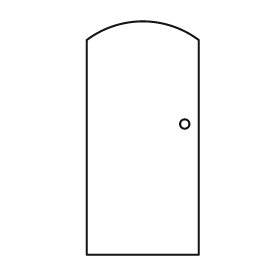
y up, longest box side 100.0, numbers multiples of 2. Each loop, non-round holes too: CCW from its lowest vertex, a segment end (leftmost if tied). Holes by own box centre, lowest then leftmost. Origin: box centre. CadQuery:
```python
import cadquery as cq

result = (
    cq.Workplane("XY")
    .moveTo(-24.0, -50.0)
    .lineTo(24.0, -50.0)
    .lineTo(24.0, 42.0)
    .threePointArc((0.0, 50.0), (-24.0, 42.0))
    .close()
    .moveTo(18.0, 6.0)
    .circle(2.0)
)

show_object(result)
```